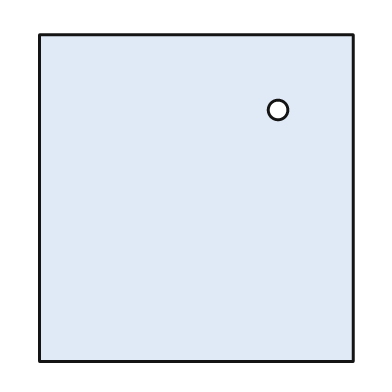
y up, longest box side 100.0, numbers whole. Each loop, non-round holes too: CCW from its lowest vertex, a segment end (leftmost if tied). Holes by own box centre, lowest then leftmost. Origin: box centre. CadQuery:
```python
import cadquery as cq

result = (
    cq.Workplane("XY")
    .moveTo(-48.0, -50.0)
    .lineTo(48.0, -50.0)
    .lineTo(48.0, 50.0)
    .lineTo(-48.0, 50.0)
    .close()
    .moveTo(25.0, 27.0)
    .circle(3.0)
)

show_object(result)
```